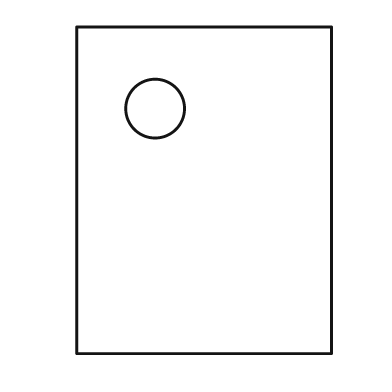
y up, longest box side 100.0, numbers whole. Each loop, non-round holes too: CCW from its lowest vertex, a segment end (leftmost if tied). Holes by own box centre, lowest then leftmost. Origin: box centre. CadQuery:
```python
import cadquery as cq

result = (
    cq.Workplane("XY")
    .moveTo(-39.0, -50.0)
    .lineTo(39.0, -50.0)
    .lineTo(39.0, 50.0)
    .lineTo(-39.0, 50.0)
    .close()
    .moveTo(-15.0, 25.0)
    .circle(9.0)
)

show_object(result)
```